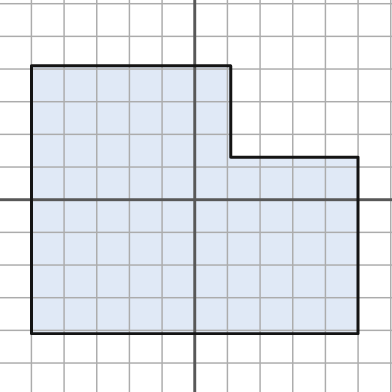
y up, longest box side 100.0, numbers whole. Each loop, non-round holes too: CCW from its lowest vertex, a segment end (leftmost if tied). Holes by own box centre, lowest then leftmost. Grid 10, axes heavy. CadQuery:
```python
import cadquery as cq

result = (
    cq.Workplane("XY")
    .moveTo(-50.0, -41.0)
    .lineTo(50.0, -41.0)
    .lineTo(50.0, 13.0)
    .lineTo(11.0, 13.0)
    .lineTo(11.0, 41.0)
    .lineTo(-50.0, 41.0)
    .close()
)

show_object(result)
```